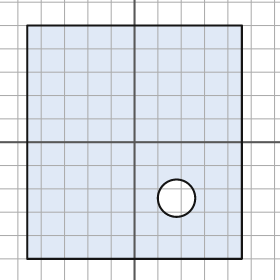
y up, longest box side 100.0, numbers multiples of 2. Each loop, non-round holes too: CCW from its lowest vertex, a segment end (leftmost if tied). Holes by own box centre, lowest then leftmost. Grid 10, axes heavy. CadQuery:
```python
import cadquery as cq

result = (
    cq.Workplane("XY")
    .moveTo(-46.0, -50.0)
    .lineTo(46.0, -50.0)
    .lineTo(46.0, 50.0)
    .lineTo(-46.0, 50.0)
    .close()
    .moveTo(18.0, -24.0)
    .circle(8.0)
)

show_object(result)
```